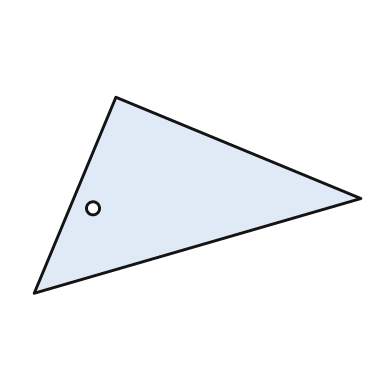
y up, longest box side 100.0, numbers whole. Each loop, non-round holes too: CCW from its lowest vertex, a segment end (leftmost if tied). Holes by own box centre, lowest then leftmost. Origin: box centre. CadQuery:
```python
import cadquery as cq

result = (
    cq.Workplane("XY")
    .moveTo(-50.0, -30.0)
    .lineTo(50.0, -1.0)
    .lineTo(-25.0, 30.0)
    .close()
    .moveTo(-32.0, -4.0)
    .circle(2.0)
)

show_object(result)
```